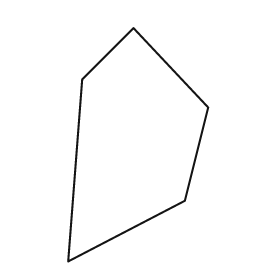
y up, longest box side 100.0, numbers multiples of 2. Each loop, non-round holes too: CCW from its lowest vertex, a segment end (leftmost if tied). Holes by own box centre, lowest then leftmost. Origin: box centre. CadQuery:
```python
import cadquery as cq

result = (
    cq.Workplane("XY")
    .moveTo(-30.0, -50.0)
    .lineTo(20.0, -24.0)
    .lineTo(30.0, 16.0)
    .lineTo(-2.0, 50.0)
    .lineTo(-24.0, 28.0)
    .close()
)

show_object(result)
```